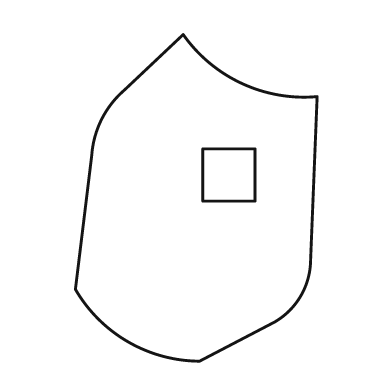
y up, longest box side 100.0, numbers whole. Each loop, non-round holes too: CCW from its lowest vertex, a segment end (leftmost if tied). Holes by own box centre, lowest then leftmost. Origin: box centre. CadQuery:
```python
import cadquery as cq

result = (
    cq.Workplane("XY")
    .moveTo(1.0, -50.0)
    .lineTo(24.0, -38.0)
    .threePointArc((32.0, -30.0), (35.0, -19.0))
    .lineTo(37.0, 31.0)
    .threePointArc((14.0, 35.0), (-4.0, 50.0))
    .lineTo(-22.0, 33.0)
    .threePointArc((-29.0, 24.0), (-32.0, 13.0))
    .lineTo(-37.0, -28.0)
    .threePointArc((-21.0, -44.0), (1.0, -50.0))
    .close()
    .moveTo(2.0, -1.0)
    .lineTo(18.0, -1.0)
    .lineTo(18.0, 15.0)
    .lineTo(2.0, 15.0)
    .close()
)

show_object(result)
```